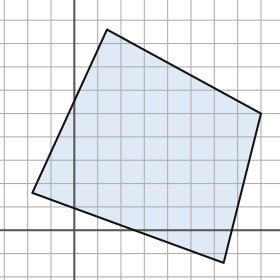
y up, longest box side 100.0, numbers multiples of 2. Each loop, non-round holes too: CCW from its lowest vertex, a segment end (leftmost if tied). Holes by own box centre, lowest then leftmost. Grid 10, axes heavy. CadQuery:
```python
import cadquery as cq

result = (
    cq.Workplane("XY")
    .moveTo(64.0, -14.0)
    .lineTo(80.0, 50.0)
    .lineTo(14.0, 86.0)
    .lineTo(-18.0, 16.0)
    .close()
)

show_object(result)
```